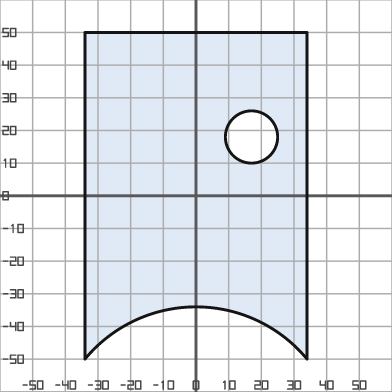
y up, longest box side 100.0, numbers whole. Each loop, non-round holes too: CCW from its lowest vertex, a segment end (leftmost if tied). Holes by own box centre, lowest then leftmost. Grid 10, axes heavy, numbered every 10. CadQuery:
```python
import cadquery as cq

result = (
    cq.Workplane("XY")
    .moveTo(-34.0, -50.0)
    .threePointArc((0.0, -34.0), (34.0, -50.0))
    .lineTo(34.0, 50.0)
    .lineTo(-34.0, 50.0)
    .close()
    .moveTo(17.0, 18.0)
    .circle(8.0)
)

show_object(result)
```